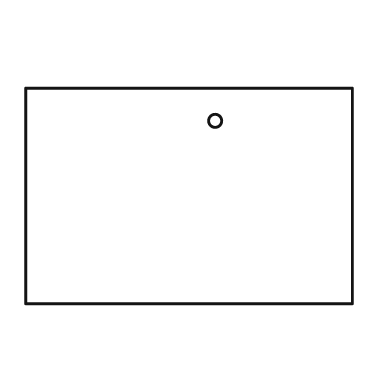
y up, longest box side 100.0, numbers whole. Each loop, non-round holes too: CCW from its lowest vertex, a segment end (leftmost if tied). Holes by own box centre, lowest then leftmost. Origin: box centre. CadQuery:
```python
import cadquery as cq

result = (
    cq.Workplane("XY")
    .moveTo(-50.0, -33.0)
    .lineTo(50.0, -33.0)
    .lineTo(50.0, 33.0)
    .lineTo(-50.0, 33.0)
    .close()
    .moveTo(8.0, 23.0)
    .circle(2.0)
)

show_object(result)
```